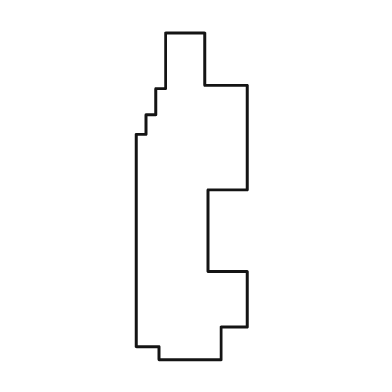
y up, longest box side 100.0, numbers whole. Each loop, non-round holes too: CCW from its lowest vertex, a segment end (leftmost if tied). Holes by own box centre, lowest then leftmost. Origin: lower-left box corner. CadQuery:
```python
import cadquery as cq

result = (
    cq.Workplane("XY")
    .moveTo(7.0, 0.0)
    .lineTo(26.0, 0.0)
    .lineTo(26.0, 10.0)
    .lineTo(34.0, 10.0)
    .lineTo(34.0, 27.0)
    .lineTo(22.0, 27.0)
    .lineTo(22.0, 52.0)
    .lineTo(34.0, 52.0)
    .lineTo(34.0, 84.0)
    .lineTo(21.0, 84.0)
    .lineTo(21.0, 100.0)
    .lineTo(9.0, 100.0)
    .lineTo(9.0, 83.0)
    .lineTo(6.0, 83.0)
    .lineTo(6.0, 75.0)
    .lineTo(3.0, 75.0)
    .lineTo(3.0, 69.0)
    .lineTo(0.0, 69.0)
    .lineTo(0.0, 4.0)
    .lineTo(7.0, 4.0)
    .close()
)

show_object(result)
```